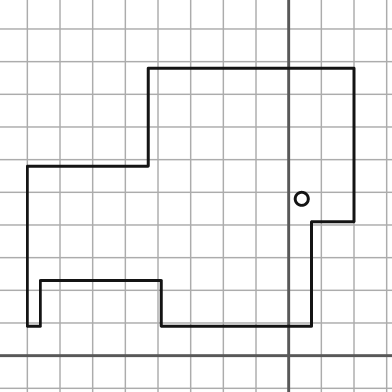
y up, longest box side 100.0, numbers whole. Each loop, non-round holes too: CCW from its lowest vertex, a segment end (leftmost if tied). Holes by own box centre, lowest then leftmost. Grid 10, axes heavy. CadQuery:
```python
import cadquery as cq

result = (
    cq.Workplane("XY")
    .moveTo(-80.0, 9.0)
    .lineTo(-76.0, 9.0)
    .lineTo(-76.0, 23.0)
    .lineTo(-39.0, 23.0)
    .lineTo(-39.0, 9.0)
    .lineTo(7.0, 9.0)
    .lineTo(7.0, 41.0)
    .lineTo(20.0, 41.0)
    .lineTo(20.0, 88.0)
    .lineTo(-43.0, 88.0)
    .lineTo(-43.0, 58.0)
    .lineTo(-80.0, 58.0)
    .close()
    .moveTo(4.0, 48.0)
    .circle(2.0)
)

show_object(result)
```